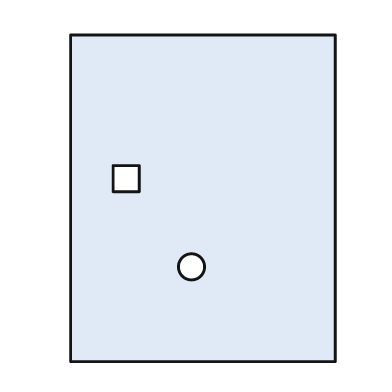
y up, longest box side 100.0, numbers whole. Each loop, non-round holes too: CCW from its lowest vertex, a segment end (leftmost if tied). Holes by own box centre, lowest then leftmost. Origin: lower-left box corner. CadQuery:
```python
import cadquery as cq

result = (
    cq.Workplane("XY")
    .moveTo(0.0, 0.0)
    .lineTo(81.0, 0.0)
    .lineTo(81.0, 100.0)
    .lineTo(0.0, 100.0)
    .close()
    .moveTo(37.0, 29.0)
    .circle(4.0)
    .moveTo(13.0, 52.0)
    .lineTo(21.0, 52.0)
    .lineTo(21.0, 60.0)
    .lineTo(13.0, 60.0)
    .close()
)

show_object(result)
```